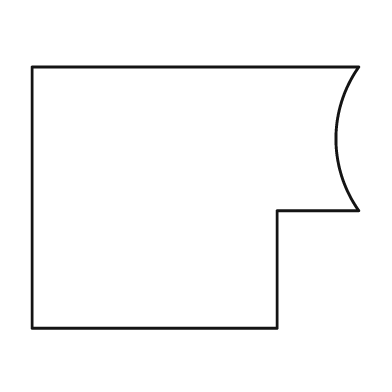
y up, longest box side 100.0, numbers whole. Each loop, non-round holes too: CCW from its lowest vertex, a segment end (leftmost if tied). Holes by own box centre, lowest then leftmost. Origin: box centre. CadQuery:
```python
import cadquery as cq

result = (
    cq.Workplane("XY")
    .moveTo(-50.0, -40.0)
    .lineTo(25.0, -40.0)
    .lineTo(25.0, -4.0)
    .lineTo(50.0, -4.0)
    .threePointArc((43.0, 18.0), (50.0, 40.0))
    .lineTo(-50.0, 40.0)
    .close()
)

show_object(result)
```